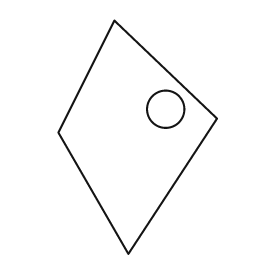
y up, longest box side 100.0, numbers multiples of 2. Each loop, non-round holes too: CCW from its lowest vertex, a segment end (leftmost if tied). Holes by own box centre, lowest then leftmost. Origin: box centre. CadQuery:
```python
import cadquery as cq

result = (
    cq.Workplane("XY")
    .moveTo(-4.0, -50.0)
    .lineTo(34.0, 8.0)
    .lineTo(-10.0, 50.0)
    .lineTo(-34.0, 2.0)
    .close()
    .moveTo(12.0, 12.0)
    .circle(8.0)
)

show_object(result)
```